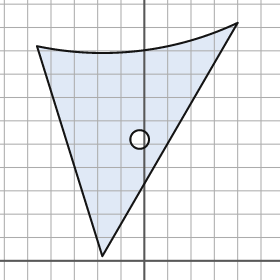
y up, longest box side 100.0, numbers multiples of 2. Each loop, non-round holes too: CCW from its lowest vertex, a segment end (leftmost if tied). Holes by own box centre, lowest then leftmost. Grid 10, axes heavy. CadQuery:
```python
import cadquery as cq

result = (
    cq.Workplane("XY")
    .moveTo(-18.0, 2.0)
    .lineTo(40.0, 102.0)
    .threePointArc((-2.0, 90.0), (-46.0, 92.0))
    .close()
    .moveTo(-2.0, 52.0)
    .circle(4.0)
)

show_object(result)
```